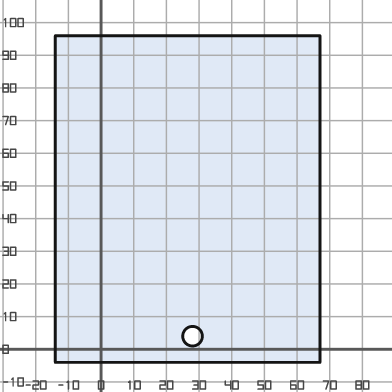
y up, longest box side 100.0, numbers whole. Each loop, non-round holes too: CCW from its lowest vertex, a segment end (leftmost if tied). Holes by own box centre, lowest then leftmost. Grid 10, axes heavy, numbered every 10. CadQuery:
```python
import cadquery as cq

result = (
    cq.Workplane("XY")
    .moveTo(-14.0, -4.0)
    .lineTo(67.0, -4.0)
    .lineTo(67.0, 96.0)
    .lineTo(-14.0, 96.0)
    .close()
    .moveTo(28.0, 4.0)
    .circle(3.0)
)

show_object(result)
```